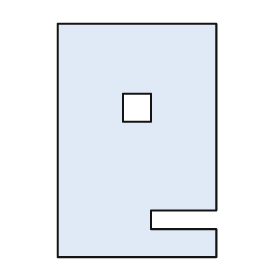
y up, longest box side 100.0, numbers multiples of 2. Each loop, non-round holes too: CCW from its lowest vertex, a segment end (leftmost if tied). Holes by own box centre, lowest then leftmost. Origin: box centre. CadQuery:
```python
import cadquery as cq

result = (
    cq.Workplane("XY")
    .moveTo(-34.0, -50.0)
    .lineTo(34.0, -50.0)
    .lineTo(34.0, -38.0)
    .lineTo(6.0, -38.0)
    .lineTo(6.0, -30.0)
    .lineTo(34.0, -30.0)
    .lineTo(34.0, 50.0)
    .lineTo(-34.0, 50.0)
    .close()
    .moveTo(-6.0, 8.0)
    .lineTo(6.0, 8.0)
    .lineTo(6.0, 20.0)
    .lineTo(-6.0, 20.0)
    .close()
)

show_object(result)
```